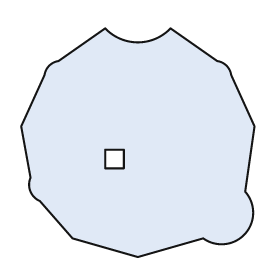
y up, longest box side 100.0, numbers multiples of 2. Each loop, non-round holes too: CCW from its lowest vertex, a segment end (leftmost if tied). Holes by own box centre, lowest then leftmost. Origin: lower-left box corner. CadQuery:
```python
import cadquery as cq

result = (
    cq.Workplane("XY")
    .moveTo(50.0, 0.0)
    .lineTo(78.0, 8.0)
    .threePointArc((96.0, 10.0), (96.0, 28.0))
    .lineTo(100.0, 56.0)
    .lineTo(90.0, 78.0)
    .threePointArc((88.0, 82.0), (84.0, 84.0))
    .lineTo(64.0, 98.0)
    .threePointArc((50.0, 92.0), (36.0, 98.0))
    .lineTo(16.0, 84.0)
    .threePointArc((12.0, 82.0), (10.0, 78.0))
    .lineTo(0.0, 56.0)
    .lineTo(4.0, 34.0)
    .threePointArc((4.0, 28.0), (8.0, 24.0))
    .lineTo(22.0, 8.0)
    .close()
    .moveTo(36.0, 38.0)
    .lineTo(44.0, 38.0)
    .lineTo(44.0, 46.0)
    .lineTo(36.0, 46.0)
    .close()
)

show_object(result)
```